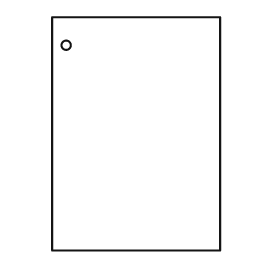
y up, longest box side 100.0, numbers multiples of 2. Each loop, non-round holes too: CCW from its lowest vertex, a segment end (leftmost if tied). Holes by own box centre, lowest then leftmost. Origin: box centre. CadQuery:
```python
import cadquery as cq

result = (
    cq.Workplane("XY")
    .moveTo(-36.0, -50.0)
    .lineTo(36.0, -50.0)
    .lineTo(36.0, 50.0)
    .lineTo(-36.0, 50.0)
    .close()
    .moveTo(-30.0, 38.0)
    .circle(2.0)
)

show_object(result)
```